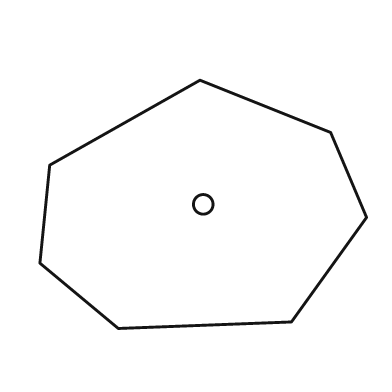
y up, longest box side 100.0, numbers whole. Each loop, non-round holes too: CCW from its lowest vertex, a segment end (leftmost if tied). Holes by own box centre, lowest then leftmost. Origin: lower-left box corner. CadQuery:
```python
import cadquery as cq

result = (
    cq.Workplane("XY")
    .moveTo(24.0, 0.0)
    .lineTo(77.0, 2.0)
    .lineTo(100.0, 34.0)
    .lineTo(89.0, 60.0)
    .lineTo(49.0, 76.0)
    .lineTo(3.0, 50.0)
    .lineTo(0.0, 20.0)
    .close()
    .moveTo(50.0, 38.0)
    .circle(3.0)
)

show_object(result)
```